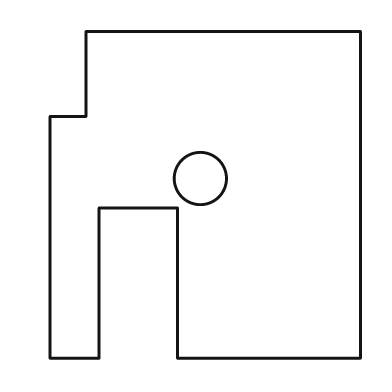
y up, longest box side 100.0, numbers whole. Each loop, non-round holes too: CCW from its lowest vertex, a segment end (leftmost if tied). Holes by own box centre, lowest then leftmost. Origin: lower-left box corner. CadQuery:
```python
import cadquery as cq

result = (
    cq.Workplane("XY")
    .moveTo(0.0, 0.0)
    .lineTo(15.0, 0.0)
    .lineTo(15.0, 46.0)
    .lineTo(39.0, 46.0)
    .lineTo(39.0, 0.0)
    .lineTo(95.0, 0.0)
    .lineTo(95.0, 100.0)
    .lineTo(11.0, 100.0)
    .lineTo(11.0, 74.0)
    .lineTo(0.0, 74.0)
    .close()
    .moveTo(46.0, 55.0)
    .circle(8.0)
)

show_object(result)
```